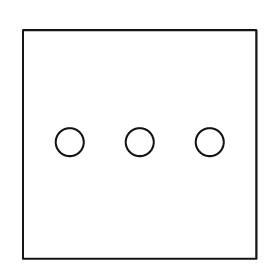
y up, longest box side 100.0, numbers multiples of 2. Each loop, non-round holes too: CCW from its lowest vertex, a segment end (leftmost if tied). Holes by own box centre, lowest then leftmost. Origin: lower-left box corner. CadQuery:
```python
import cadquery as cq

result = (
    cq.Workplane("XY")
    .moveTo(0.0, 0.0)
    .lineTo(100.0, 0.0)
    .lineTo(100.0, 98.0)
    .lineTo(0.0, 98.0)
    .close()
    .moveTo(20.0, 50.0)
    .circle(6.0)
    .moveTo(50.0, 50.0)
    .circle(6.0)
    .moveTo(80.0, 50.0)
    .circle(6.0)
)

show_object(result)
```